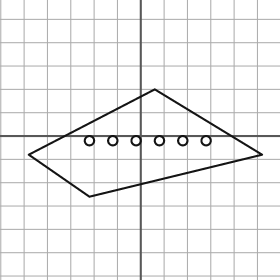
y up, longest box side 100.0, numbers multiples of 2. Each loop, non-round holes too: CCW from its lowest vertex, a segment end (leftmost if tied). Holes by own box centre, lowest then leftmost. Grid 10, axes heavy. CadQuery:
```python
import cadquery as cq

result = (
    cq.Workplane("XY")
    .moveTo(-22.0, -26.0)
    .lineTo(52.0, -8.0)
    .lineTo(6.0, 20.0)
    .lineTo(-48.0, -8.0)
    .close()
    .moveTo(-22.0, -2.0)
    .circle(2.0)
    .moveTo(-12.0, -2.0)
    .circle(2.0)
    .moveTo(-2.0, -2.0)
    .circle(2.0)
    .moveTo(8.0, -2.0)
    .circle(2.0)
    .moveTo(18.0, -2.0)
    .circle(2.0)
    .moveTo(28.0, -2.0)
    .circle(2.0)
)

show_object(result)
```